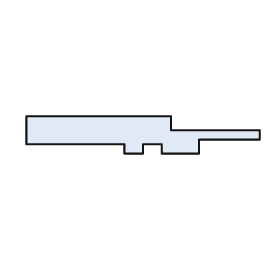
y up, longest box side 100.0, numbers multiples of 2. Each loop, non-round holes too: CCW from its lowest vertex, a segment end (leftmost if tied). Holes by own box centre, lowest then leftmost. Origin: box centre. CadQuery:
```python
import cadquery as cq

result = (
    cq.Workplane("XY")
    .moveTo(-8.0, -8.0)
    .lineTo(0.0, -8.0)
    .lineTo(0.0, -4.0)
    .lineTo(8.0, -4.0)
    .lineTo(8.0, -8.0)
    .lineTo(24.0, -8.0)
    .lineTo(24.0, -2.0)
    .lineTo(50.0, -2.0)
    .lineTo(50.0, 2.0)
    .lineTo(12.0, 2.0)
    .lineTo(12.0, 8.0)
    .lineTo(-50.0, 8.0)
    .lineTo(-50.0, -4.0)
    .lineTo(-8.0, -4.0)
    .close()
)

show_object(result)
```